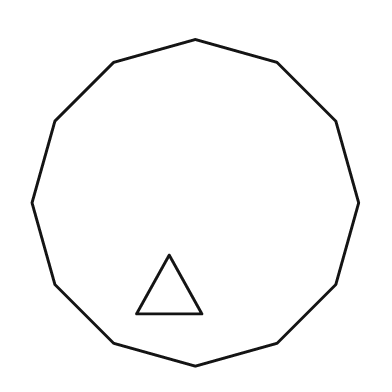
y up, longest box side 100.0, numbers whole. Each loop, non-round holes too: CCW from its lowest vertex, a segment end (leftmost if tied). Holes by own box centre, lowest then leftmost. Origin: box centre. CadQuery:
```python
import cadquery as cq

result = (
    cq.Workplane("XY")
    .moveTo(0.0, -50.0)
    .lineTo(25.0, -43.0)
    .lineTo(43.0, -25.0)
    .lineTo(50.0, 0.0)
    .lineTo(43.0, 25.0)
    .lineTo(25.0, 43.0)
    .lineTo(0.0, 50.0)
    .lineTo(-25.0, 43.0)
    .lineTo(-43.0, 25.0)
    .lineTo(-50.0, 0.0)
    .lineTo(-43.0, -25.0)
    .lineTo(-25.0, -43.0)
    .close()
    .moveTo(-18.0, -34.0)
    .lineTo(2.0, -34.0)
    .lineTo(-8.0, -16.0)
    .close()
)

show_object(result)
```